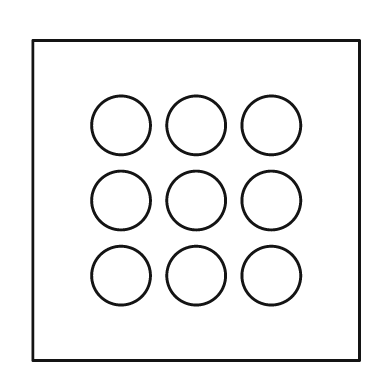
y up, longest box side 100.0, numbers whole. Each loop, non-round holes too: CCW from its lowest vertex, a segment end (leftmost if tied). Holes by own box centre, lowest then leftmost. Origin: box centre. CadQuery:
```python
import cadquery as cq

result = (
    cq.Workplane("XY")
    .moveTo(-50.0, -49.0)
    .lineTo(50.0, -49.0)
    .lineTo(50.0, 49.0)
    .lineTo(-50.0, 49.0)
    .close()
    .moveTo(-23.0, -23.0)
    .circle(9.0)
    .moveTo(0.0, -23.0)
    .circle(9.0)
    .moveTo(23.0, -23.0)
    .circle(9.0)
    .moveTo(-23.0, 0.0)
    .circle(9.0)
    .moveTo(0.0, 0.0)
    .circle(9.0)
    .moveTo(23.0, 0.0)
    .circle(9.0)
    .moveTo(-23.0, 23.0)
    .circle(9.0)
    .moveTo(0.0, 23.0)
    .circle(9.0)
    .moveTo(23.0, 23.0)
    .circle(9.0)
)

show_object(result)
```